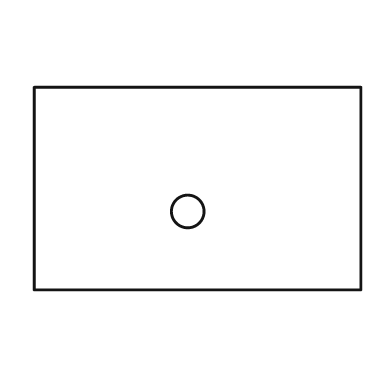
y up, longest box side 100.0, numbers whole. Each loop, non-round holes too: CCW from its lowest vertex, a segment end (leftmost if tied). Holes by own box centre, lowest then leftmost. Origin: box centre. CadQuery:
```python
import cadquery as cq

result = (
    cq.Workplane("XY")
    .moveTo(-50.0, -31.0)
    .lineTo(50.0, -31.0)
    .lineTo(50.0, 31.0)
    .lineTo(-50.0, 31.0)
    .close()
    .moveTo(-3.0, -7.0)
    .circle(5.0)
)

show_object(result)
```